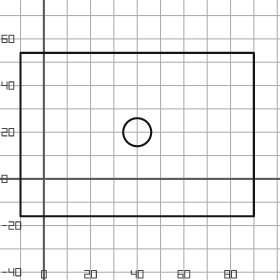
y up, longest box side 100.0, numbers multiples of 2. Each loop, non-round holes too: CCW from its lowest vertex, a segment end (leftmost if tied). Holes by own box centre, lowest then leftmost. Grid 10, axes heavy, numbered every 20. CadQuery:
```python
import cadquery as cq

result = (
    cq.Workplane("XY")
    .moveTo(-10.0, -16.0)
    .lineTo(90.0, -16.0)
    .lineTo(90.0, 54.0)
    .lineTo(-10.0, 54.0)
    .close()
    .moveTo(40.0, 20.0)
    .circle(6.0)
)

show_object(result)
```